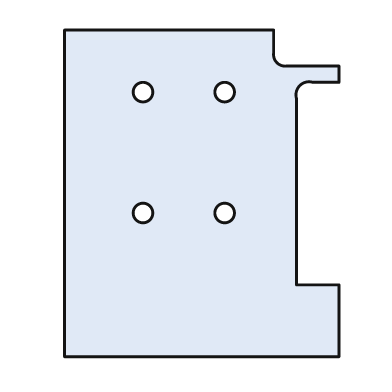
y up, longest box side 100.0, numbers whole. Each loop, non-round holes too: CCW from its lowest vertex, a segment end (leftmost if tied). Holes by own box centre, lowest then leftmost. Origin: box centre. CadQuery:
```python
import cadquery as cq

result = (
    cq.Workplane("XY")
    .moveTo(-42.0, -50.0)
    .lineTo(42.0, -50.0)
    .lineTo(42.0, -28.0)
    .lineTo(29.0, -28.0)
    .lineTo(29.0, 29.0)
    .threePointArc((30.0, 33.0), (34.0, 34.0))
    .lineTo(42.0, 34.0)
    .lineTo(42.0, 39.0)
    .lineTo(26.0, 39.0)
    .threePointArc((23.0, 40.0), (22.0, 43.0))
    .lineTo(22.0, 50.0)
    .lineTo(-42.0, 50.0)
    .close()
    .moveTo(-18.0, -6.0)
    .circle(3.0)
    .moveTo(7.0, -6.0)
    .circle(3.0)
    .moveTo(-18.0, 31.0)
    .circle(3.0)
    .moveTo(7.0, 31.0)
    .circle(3.0)
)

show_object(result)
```